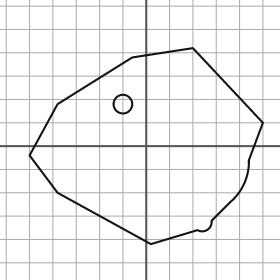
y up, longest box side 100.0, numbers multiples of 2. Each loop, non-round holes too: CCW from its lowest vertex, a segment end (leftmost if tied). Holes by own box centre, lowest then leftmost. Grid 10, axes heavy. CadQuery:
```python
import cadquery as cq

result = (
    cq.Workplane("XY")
    .moveTo(2.0, -42.0)
    .lineTo(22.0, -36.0)
    .threePointArc((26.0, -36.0), (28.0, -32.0))
    .lineTo(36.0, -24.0)
    .threePointArc((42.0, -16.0), (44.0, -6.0))
    .lineTo(50.0, 10.0)
    .lineTo(20.0, 42.0)
    .lineTo(-6.0, 38.0)
    .lineTo(-38.0, 18.0)
    .lineTo(-50.0, -4.0)
    .lineTo(-38.0, -20.0)
    .close()
    .moveTo(-10.0, 18.0)
    .circle(4.0)
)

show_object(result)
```